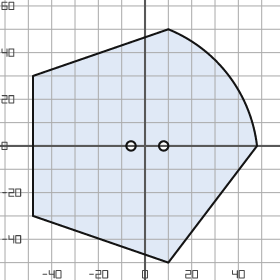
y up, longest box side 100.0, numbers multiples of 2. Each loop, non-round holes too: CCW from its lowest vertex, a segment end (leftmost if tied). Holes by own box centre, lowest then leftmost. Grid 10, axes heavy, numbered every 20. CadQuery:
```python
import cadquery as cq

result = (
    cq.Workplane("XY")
    .moveTo(10.0, -50.0)
    .lineTo(48.0, 0.0)
    .threePointArc((36.0, 30.0), (10.0, 50.0))
    .lineTo(-48.0, 30.0)
    .lineTo(-48.0, -30.0)
    .close()
    .moveTo(-6.0, 0.0)
    .circle(2.0)
    .moveTo(8.0, 0.0)
    .circle(2.0)
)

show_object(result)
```